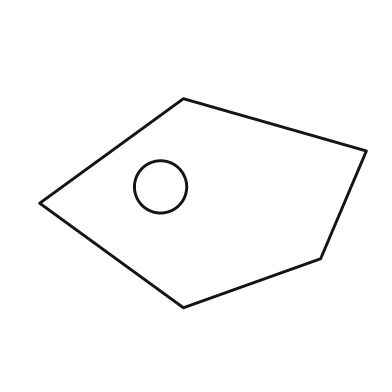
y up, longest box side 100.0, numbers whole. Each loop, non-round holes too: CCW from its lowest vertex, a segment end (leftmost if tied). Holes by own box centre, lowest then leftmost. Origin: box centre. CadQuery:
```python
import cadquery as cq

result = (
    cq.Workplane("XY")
    .moveTo(-6.0, -32.0)
    .lineTo(36.0, -17.0)
    .lineTo(50.0, 16.0)
    .lineTo(-6.0, 32.0)
    .lineTo(-50.0, 0.0)
    .close()
    .moveTo(-13.0, 5.0)
    .circle(8.0)
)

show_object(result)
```